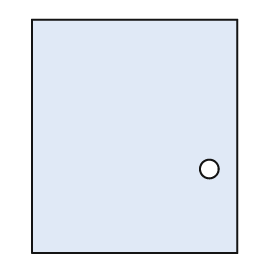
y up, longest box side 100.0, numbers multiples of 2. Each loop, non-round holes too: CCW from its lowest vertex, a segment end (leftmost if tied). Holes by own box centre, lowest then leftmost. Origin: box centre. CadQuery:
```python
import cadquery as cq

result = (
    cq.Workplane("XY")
    .moveTo(-44.0, -50.0)
    .lineTo(44.0, -50.0)
    .lineTo(44.0, 50.0)
    .lineTo(-44.0, 50.0)
    .close()
    .moveTo(32.0, -14.0)
    .circle(4.0)
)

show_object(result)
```